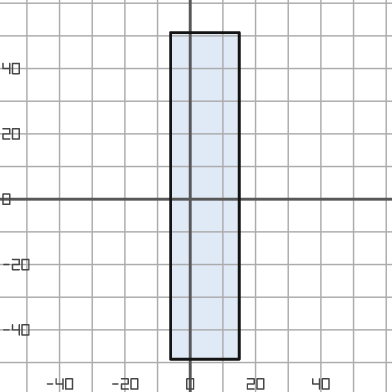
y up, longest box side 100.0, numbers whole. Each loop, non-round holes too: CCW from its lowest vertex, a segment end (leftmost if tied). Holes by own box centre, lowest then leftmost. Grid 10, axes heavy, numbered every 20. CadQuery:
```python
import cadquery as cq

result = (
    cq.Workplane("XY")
    .moveTo(-6.0, -49.0)
    .lineTo(15.0, -49.0)
    .lineTo(15.0, 51.0)
    .lineTo(-6.0, 51.0)
    .close()
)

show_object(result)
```